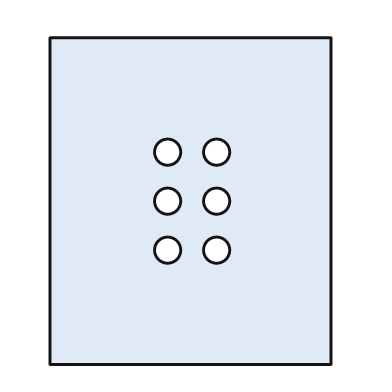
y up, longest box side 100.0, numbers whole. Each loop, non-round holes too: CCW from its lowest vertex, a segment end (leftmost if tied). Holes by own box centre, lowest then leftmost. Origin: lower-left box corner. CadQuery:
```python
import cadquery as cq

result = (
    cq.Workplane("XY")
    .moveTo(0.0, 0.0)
    .lineTo(86.0, 0.0)
    .lineTo(86.0, 100.0)
    .lineTo(0.0, 100.0)
    .close()
    .moveTo(36.0, 35.0)
    .circle(4.0)
    .moveTo(51.0, 35.0)
    .circle(4.0)
    .moveTo(36.0, 50.0)
    .circle(4.0)
    .moveTo(51.0, 50.0)
    .circle(4.0)
    .moveTo(36.0, 65.0)
    .circle(4.0)
    .moveTo(51.0, 65.0)
    .circle(4.0)
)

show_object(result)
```